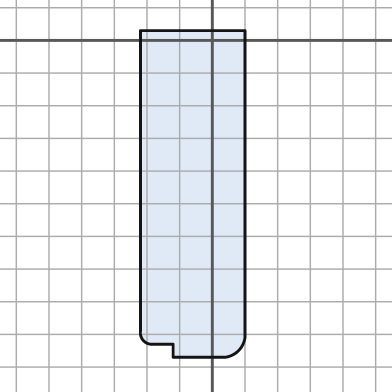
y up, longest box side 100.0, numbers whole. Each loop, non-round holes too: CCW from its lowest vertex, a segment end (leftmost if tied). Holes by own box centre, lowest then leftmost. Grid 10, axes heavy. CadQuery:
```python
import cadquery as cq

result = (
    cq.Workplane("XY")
    .moveTo(-12.0, -97.0)
    .lineTo(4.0, -97.0)
    .threePointArc((8.0, -95.0), (10.0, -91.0))
    .lineTo(10.0, 3.0)
    .lineTo(-22.0, 3.0)
    .lineTo(-22.0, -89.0)
    .threePointArc((-21.0, -92.0), (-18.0, -93.0))
    .lineTo(-12.0, -93.0)
    .close()
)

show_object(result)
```